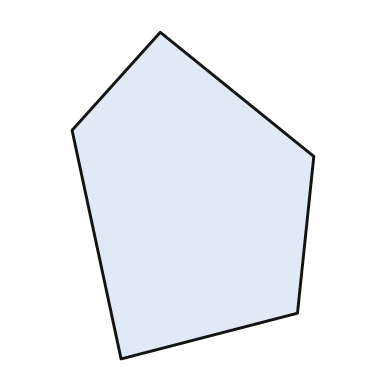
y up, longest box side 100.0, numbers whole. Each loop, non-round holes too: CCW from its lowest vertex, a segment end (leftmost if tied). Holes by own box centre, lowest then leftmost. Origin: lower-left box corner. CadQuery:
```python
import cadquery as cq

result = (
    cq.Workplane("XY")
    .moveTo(15.0, 0.0)
    .lineTo(69.0, 14.0)
    .lineTo(74.0, 62.0)
    .lineTo(27.0, 100.0)
    .lineTo(0.0, 70.0)
    .close()
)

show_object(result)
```